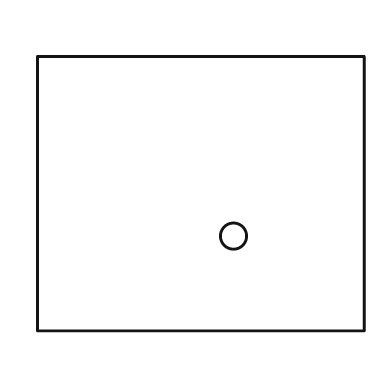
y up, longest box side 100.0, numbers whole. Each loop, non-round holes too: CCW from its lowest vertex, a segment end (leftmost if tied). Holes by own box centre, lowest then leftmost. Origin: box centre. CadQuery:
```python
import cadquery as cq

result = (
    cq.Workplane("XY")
    .moveTo(-50.0, -42.0)
    .lineTo(50.0, -42.0)
    .lineTo(50.0, 42.0)
    .lineTo(-50.0, 42.0)
    .close()
    .moveTo(10.0, -13.0)
    .circle(4.0)
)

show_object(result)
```